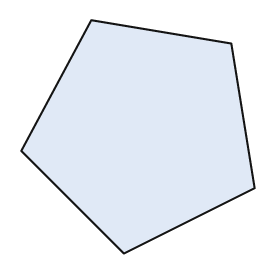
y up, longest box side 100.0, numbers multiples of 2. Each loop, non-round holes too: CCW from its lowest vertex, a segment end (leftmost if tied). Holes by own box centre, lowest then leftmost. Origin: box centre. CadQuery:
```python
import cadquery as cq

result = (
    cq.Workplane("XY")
    .moveTo(-6.0, -50.0)
    .lineTo(50.0, -22.0)
    .lineTo(40.0, 40.0)
    .lineTo(-20.0, 50.0)
    .lineTo(-50.0, -6.0)
    .close()
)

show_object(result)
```